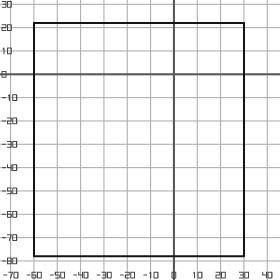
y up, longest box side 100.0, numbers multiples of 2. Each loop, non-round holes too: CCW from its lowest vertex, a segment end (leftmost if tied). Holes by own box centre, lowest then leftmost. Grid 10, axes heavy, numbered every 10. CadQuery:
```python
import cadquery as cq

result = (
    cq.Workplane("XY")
    .moveTo(-60.0, -78.0)
    .lineTo(30.0, -78.0)
    .lineTo(30.0, 22.0)
    .lineTo(-60.0, 22.0)
    .close()
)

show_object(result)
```